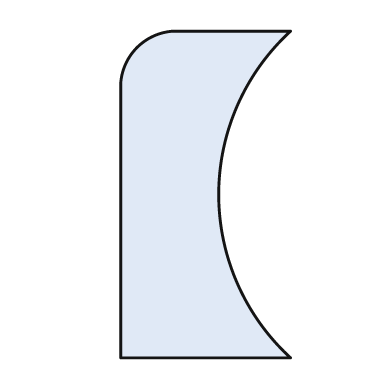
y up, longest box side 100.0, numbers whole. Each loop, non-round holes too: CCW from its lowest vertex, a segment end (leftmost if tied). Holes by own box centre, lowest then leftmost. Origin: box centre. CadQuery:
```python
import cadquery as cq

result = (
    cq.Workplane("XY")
    .moveTo(-26.0, -50.0)
    .lineTo(26.0, -50.0)
    .threePointArc((4.0, 0.0), (26.0, 50.0))
    .lineTo(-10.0, 50.0)
    .threePointArc((-21.0, 45.0), (-26.0, 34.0))
    .close()
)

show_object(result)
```